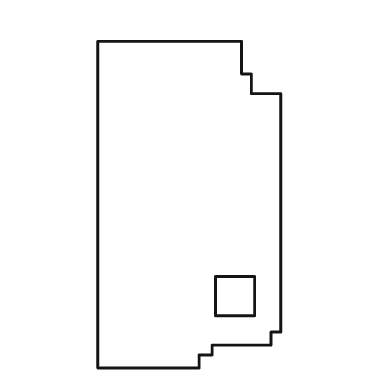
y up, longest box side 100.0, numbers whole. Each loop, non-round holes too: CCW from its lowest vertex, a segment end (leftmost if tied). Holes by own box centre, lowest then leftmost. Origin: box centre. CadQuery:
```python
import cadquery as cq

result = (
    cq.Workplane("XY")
    .moveTo(-28.0, -50.0)
    .lineTo(3.0, -50.0)
    .lineTo(3.0, -46.0)
    .lineTo(7.0, -46.0)
    .lineTo(7.0, -43.0)
    .lineTo(25.0, -43.0)
    .lineTo(25.0, -39.0)
    .lineTo(28.0, -39.0)
    .lineTo(28.0, 34.0)
    .lineTo(19.0, 34.0)
    .lineTo(19.0, 40.0)
    .lineTo(16.0, 40.0)
    .lineTo(16.0, 50.0)
    .lineTo(-28.0, 50.0)
    .close()
    .moveTo(8.0, -34.0)
    .lineTo(20.0, -34.0)
    .lineTo(20.0, -22.0)
    .lineTo(8.0, -22.0)
    .close()
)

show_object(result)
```